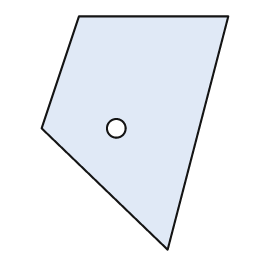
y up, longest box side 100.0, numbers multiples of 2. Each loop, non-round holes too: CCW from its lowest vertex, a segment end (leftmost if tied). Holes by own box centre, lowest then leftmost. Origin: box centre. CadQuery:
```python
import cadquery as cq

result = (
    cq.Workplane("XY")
    .moveTo(14.0, -50.0)
    .lineTo(40.0, 50.0)
    .lineTo(-24.0, 50.0)
    .lineTo(-40.0, 2.0)
    .close()
    .moveTo(-8.0, 2.0)
    .circle(4.0)
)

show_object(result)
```